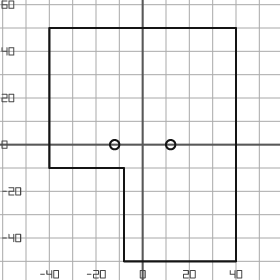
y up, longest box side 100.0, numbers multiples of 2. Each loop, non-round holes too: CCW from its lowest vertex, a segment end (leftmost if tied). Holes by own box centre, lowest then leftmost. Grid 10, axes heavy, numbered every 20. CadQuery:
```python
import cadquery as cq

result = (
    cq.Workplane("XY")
    .moveTo(-8.0, -50.0)
    .lineTo(40.0, -50.0)
    .lineTo(40.0, 50.0)
    .lineTo(-40.0, 50.0)
    .lineTo(-40.0, -10.0)
    .lineTo(-8.0, -10.0)
    .close()
    .moveTo(-12.0, 0.0)
    .circle(2.0)
    .moveTo(12.0, 0.0)
    .circle(2.0)
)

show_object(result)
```